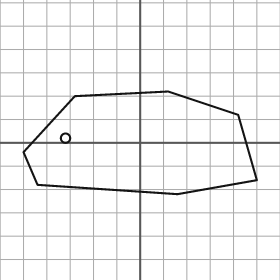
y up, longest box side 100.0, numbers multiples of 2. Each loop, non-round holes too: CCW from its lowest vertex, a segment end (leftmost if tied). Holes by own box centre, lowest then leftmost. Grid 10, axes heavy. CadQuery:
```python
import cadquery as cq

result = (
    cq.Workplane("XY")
    .moveTo(16.0, -22.0)
    .lineTo(50.0, -16.0)
    .lineTo(42.0, 12.0)
    .lineTo(12.0, 22.0)
    .lineTo(-28.0, 20.0)
    .lineTo(-50.0, -4.0)
    .lineTo(-44.0, -18.0)
    .close()
    .moveTo(-32.0, 2.0)
    .circle(2.0)
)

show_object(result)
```